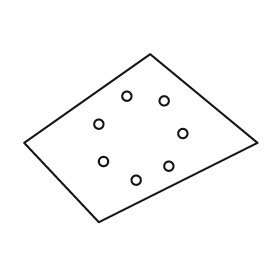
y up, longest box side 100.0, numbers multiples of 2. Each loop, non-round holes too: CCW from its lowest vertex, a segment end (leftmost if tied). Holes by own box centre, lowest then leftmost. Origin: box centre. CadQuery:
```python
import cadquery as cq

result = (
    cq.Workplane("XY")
    .moveTo(-18.0, -36.0)
    .lineTo(50.0, -2.0)
    .lineTo(4.0, 36.0)
    .lineTo(-50.0, -2.0)
    .close()
    .moveTo(-2.0, -18.0)
    .circle(2.0)
    .moveTo(12.0, -12.0)
    .circle(2.0)
    .moveTo(-16.0, -10.0)
    .circle(2.0)
    .moveTo(18.0, 2.0)
    .circle(2.0)
    .moveTo(-18.0, 6.0)
    .circle(2.0)
    .moveTo(10.0, 16.0)
    .circle(2.0)
    .moveTo(-6.0, 18.0)
    .circle(2.0)
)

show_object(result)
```